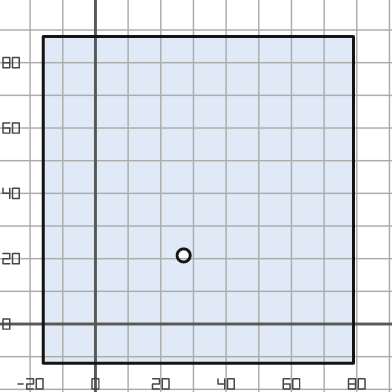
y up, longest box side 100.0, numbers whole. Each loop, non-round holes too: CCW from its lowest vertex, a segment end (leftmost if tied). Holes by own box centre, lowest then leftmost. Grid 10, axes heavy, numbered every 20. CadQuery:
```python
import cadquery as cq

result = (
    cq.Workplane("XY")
    .moveTo(-16.0, -12.0)
    .lineTo(79.0, -12.0)
    .lineTo(79.0, 88.0)
    .lineTo(-16.0, 88.0)
    .close()
    .moveTo(27.0, 21.0)
    .circle(2.0)
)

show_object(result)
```